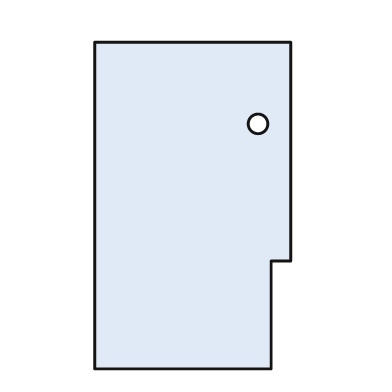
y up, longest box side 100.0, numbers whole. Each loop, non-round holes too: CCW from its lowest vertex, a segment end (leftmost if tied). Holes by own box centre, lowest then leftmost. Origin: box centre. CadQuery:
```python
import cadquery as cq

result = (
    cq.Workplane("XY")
    .moveTo(-30.0, -50.0)
    .lineTo(24.0, -50.0)
    .lineTo(24.0, -17.0)
    .lineTo(30.0, -17.0)
    .lineTo(30.0, 50.0)
    .lineTo(-30.0, 50.0)
    .close()
    .moveTo(20.0, 25.0)
    .circle(3.0)
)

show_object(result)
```